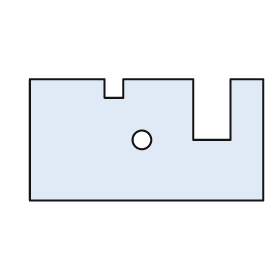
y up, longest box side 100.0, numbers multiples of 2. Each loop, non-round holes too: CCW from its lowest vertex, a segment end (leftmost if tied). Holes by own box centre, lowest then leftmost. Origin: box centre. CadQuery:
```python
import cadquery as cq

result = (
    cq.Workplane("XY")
    .moveTo(-50.0, -26.0)
    .lineTo(50.0, -26.0)
    .lineTo(50.0, 26.0)
    .lineTo(36.0, 26.0)
    .lineTo(36.0, 0.0)
    .lineTo(20.0, 0.0)
    .lineTo(20.0, 26.0)
    .lineTo(-10.0, 26.0)
    .lineTo(-10.0, 18.0)
    .lineTo(-18.0, 18.0)
    .lineTo(-18.0, 26.0)
    .lineTo(-50.0, 26.0)
    .close()
    .moveTo(-2.0, 0.0)
    .circle(4.0)
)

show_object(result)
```